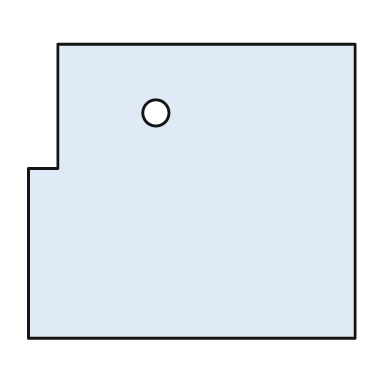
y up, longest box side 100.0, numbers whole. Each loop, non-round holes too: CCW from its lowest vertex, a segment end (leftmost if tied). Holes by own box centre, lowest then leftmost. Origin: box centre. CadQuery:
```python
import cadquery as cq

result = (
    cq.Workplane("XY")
    .moveTo(-50.0, -45.0)
    .lineTo(50.0, -45.0)
    .lineTo(50.0, 45.0)
    .lineTo(-41.0, 45.0)
    .lineTo(-41.0, 7.0)
    .lineTo(-50.0, 7.0)
    .close()
    .moveTo(-11.0, 24.0)
    .circle(4.0)
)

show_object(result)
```